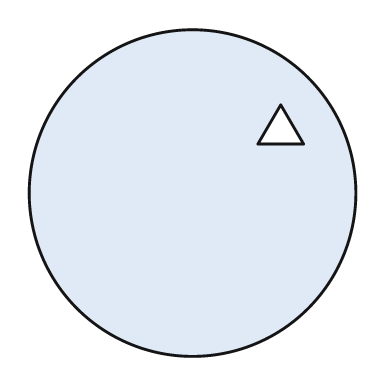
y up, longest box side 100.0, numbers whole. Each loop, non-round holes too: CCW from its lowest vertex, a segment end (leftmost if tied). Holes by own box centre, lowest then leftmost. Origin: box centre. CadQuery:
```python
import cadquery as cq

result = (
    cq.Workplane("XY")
    .moveTo(0.0, 0.0)
    .circle(50.0)
    .moveTo(20.0, 15.0)
    .lineTo(34.0, 15.0)
    .lineTo(27.0, 27.0)
    .close()
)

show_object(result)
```